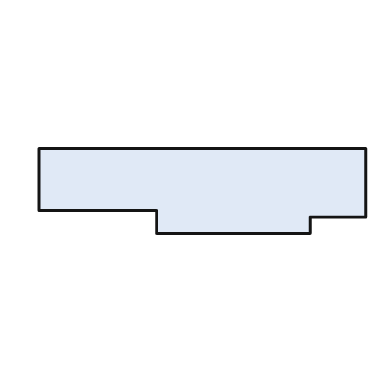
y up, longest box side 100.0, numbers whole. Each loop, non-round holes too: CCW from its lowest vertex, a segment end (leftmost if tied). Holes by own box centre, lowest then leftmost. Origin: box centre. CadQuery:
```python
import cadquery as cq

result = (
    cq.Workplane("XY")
    .moveTo(-14.0, -13.0)
    .lineTo(33.0, -13.0)
    .lineTo(33.0, -8.0)
    .lineTo(50.0, -8.0)
    .lineTo(50.0, 13.0)
    .lineTo(-50.0, 13.0)
    .lineTo(-50.0, -6.0)
    .lineTo(-14.0, -6.0)
    .close()
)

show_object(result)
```